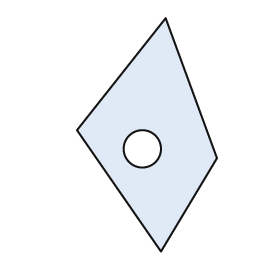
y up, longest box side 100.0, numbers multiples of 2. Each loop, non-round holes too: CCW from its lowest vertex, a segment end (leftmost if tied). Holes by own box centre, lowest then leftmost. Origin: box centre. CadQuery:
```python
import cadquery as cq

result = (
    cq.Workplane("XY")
    .moveTo(6.0, -50.0)
    .lineTo(30.0, -10.0)
    .lineTo(8.0, 50.0)
    .lineTo(-30.0, 2.0)
    .close()
    .moveTo(-2.0, -6.0)
    .circle(8.0)
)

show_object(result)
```